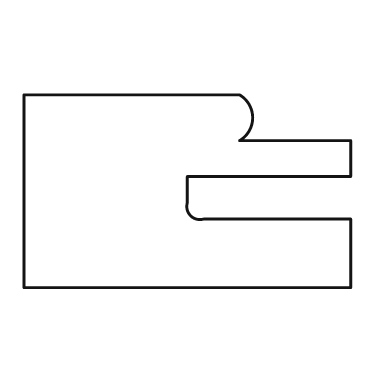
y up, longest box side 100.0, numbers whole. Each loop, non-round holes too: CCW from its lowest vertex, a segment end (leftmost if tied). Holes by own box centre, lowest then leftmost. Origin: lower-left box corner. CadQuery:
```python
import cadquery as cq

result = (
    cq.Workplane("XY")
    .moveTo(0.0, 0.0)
    .lineTo(100.0, 0.0)
    .lineTo(100.0, 21.0)
    .lineTo(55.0, 21.0)
    .threePointArc((51.0, 22.0), (50.0, 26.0))
    .lineTo(50.0, 34.0)
    .lineTo(100.0, 34.0)
    .lineTo(100.0, 45.0)
    .lineTo(66.0, 45.0)
    .threePointArc((70.0, 52.0), (66.0, 59.0))
    .lineTo(0.0, 59.0)
    .close()
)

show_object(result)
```